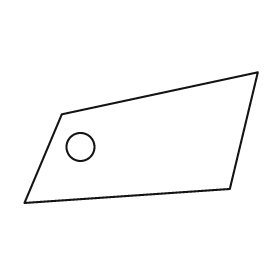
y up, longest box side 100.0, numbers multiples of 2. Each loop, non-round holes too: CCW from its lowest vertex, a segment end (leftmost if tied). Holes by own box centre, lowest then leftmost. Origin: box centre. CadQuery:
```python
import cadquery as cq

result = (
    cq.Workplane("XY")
    .moveTo(-50.0, -28.0)
    .lineTo(38.0, -22.0)
    .lineTo(50.0, 28.0)
    .lineTo(-34.0, 10.0)
    .close()
    .moveTo(-26.0, -4.0)
    .circle(6.0)
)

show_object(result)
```